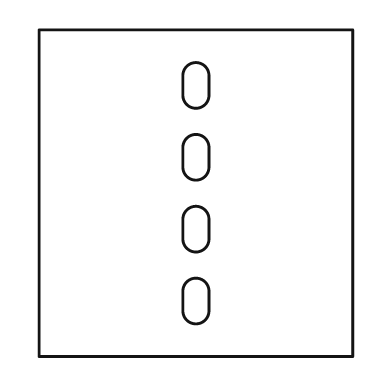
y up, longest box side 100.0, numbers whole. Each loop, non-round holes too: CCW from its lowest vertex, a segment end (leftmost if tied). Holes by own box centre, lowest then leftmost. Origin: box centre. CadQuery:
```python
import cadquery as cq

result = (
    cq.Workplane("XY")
    .moveTo(-48.0, -50.0)
    .lineTo(48.0, -50.0)
    .lineTo(48.0, 50.0)
    .lineTo(-48.0, 50.0)
    .close()
    .moveTo(-4.0, -36.0)
    .threePointArc((0.0, -40.0), (4.0, -36.0))
    .lineTo(4.0, -30.0)
    .threePointArc((0.0, -26.0), (-4.0, -30.0))
    .close()
    .moveTo(-4.0, -14.0)
    .threePointArc((0.0, -18.0), (4.0, -14.0))
    .lineTo(4.0, -8.0)
    .threePointArc((0.0, -4.0), (-4.0, -8.0))
    .close()
    .moveTo(-4.0, 8.0)
    .threePointArc((0.0, 4.0), (4.0, 8.0))
    .lineTo(4.0, 14.0)
    .threePointArc((0.0, 18.0), (-4.0, 14.0))
    .close()
    .moveTo(-4.0, 30.0)
    .threePointArc((0.0, 26.0), (4.0, 30.0))
    .lineTo(4.0, 36.0)
    .threePointArc((0.0, 40.0), (-4.0, 36.0))
    .close()
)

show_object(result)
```